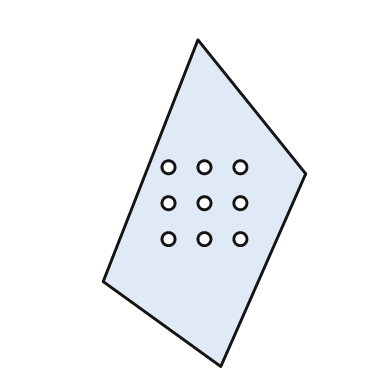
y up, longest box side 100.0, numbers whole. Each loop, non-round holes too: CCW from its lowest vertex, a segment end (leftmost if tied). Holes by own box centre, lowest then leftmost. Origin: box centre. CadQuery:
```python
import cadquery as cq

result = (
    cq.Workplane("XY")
    .moveTo(5.0, -50.0)
    .lineTo(31.0, 9.0)
    .lineTo(-2.0, 50.0)
    .lineTo(-31.0, -24.0)
    .close()
    .moveTo(-11.0, -11.0)
    .circle(2.0)
    .moveTo(0.0, -11.0)
    .circle(2.0)
    .moveTo(11.0, -11.0)
    .circle(2.0)
    .moveTo(-11.0, 0.0)
    .circle(2.0)
    .moveTo(0.0, 0.0)
    .circle(2.0)
    .moveTo(11.0, 0.0)
    .circle(2.0)
    .moveTo(-11.0, 11.0)
    .circle(2.0)
    .moveTo(0.0, 11.0)
    .circle(2.0)
    .moveTo(11.0, 11.0)
    .circle(2.0)
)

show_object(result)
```